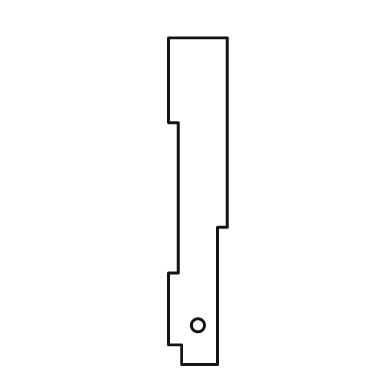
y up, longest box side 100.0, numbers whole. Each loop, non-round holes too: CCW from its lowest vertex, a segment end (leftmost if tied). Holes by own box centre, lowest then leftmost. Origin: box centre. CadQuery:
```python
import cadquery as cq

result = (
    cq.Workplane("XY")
    .moveTo(-5.0, -50.0)
    .lineTo(6.0, -50.0)
    .lineTo(6.0, -8.0)
    .lineTo(9.0, -8.0)
    .lineTo(9.0, 50.0)
    .lineTo(-9.0, 50.0)
    .lineTo(-9.0, 24.0)
    .lineTo(-6.0, 24.0)
    .lineTo(-6.0, -22.0)
    .lineTo(-9.0, -22.0)
    .lineTo(-9.0, -44.0)
    .lineTo(-5.0, -44.0)
    .close()
    .moveTo(0.0, -38.0)
    .circle(2.0)
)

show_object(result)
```